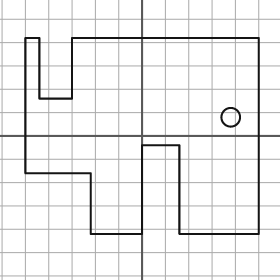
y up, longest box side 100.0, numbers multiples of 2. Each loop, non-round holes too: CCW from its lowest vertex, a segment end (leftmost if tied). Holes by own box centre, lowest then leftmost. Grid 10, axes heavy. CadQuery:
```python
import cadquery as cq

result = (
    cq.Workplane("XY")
    .moveTo(-22.0, -42.0)
    .lineTo(0.0, -42.0)
    .lineTo(0.0, -4.0)
    .lineTo(16.0, -4.0)
    .lineTo(16.0, -42.0)
    .lineTo(50.0, -42.0)
    .lineTo(50.0, 42.0)
    .lineTo(-30.0, 42.0)
    .lineTo(-30.0, 16.0)
    .lineTo(-44.0, 16.0)
    .lineTo(-44.0, 42.0)
    .lineTo(-50.0, 42.0)
    .lineTo(-50.0, -16.0)
    .lineTo(-22.0, -16.0)
    .close()
    .moveTo(38.0, 8.0)
    .circle(4.0)
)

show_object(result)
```